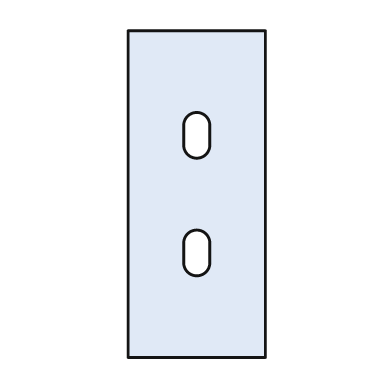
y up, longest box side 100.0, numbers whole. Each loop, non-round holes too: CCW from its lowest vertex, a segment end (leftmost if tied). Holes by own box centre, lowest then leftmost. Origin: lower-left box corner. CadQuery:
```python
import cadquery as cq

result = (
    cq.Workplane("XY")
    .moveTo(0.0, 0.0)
    .lineTo(42.0, 0.0)
    .lineTo(42.0, 100.0)
    .lineTo(0.0, 100.0)
    .close()
    .moveTo(17.0, 29.0)
    .threePointArc((21.0, 25.0), (25.0, 29.0))
    .lineTo(25.0, 35.0)
    .threePointArc((21.0, 39.0), (17.0, 35.0))
    .close()
    .moveTo(17.0, 65.0)
    .threePointArc((21.0, 61.0), (25.0, 65.0))
    .lineTo(25.0, 71.0)
    .threePointArc((21.0, 75.0), (17.0, 71.0))
    .close()
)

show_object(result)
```